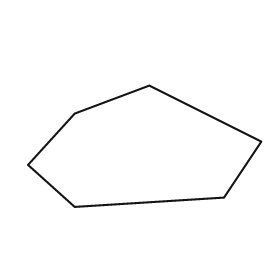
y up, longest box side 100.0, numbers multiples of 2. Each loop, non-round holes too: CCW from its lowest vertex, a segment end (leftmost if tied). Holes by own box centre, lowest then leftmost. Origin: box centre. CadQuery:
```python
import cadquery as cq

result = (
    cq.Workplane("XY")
    .moveTo(-30.0, -26.0)
    .lineTo(34.0, -22.0)
    .lineTo(50.0, 2.0)
    .lineTo(2.0, 26.0)
    .lineTo(-30.0, 14.0)
    .lineTo(-50.0, -8.0)
    .close()
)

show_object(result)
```